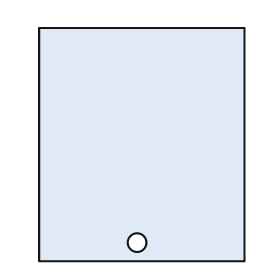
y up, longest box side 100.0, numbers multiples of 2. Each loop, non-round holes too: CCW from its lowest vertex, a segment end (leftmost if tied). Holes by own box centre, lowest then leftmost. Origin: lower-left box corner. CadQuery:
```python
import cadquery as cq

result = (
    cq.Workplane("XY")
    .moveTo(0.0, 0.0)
    .lineTo(88.0, 0.0)
    .lineTo(88.0, 100.0)
    .lineTo(0.0, 100.0)
    .close()
    .moveTo(42.0, 8.0)
    .circle(4.0)
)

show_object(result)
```